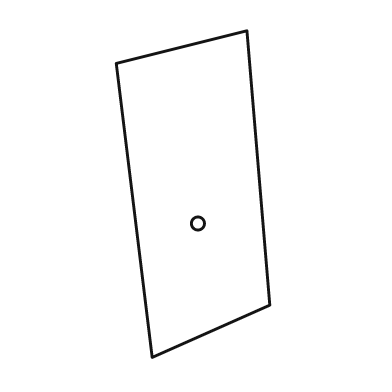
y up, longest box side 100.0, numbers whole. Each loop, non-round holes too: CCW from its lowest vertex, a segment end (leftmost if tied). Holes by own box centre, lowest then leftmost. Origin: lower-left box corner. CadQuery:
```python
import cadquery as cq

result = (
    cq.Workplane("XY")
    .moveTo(11.0, 0.0)
    .lineTo(47.0, 16.0)
    .lineTo(40.0, 100.0)
    .lineTo(0.0, 90.0)
    .close()
    .moveTo(25.0, 41.0)
    .circle(2.0)
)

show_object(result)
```